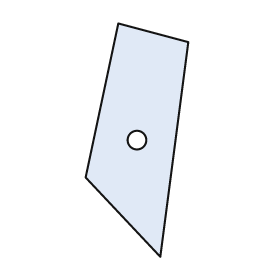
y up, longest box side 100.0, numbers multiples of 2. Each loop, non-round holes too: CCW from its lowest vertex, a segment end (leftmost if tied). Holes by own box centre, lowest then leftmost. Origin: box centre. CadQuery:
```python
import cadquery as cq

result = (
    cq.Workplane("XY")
    .moveTo(10.0, -50.0)
    .lineTo(22.0, 42.0)
    .lineTo(-8.0, 50.0)
    .lineTo(-22.0, -16.0)
    .close()
    .moveTo(0.0, 0.0)
    .circle(4.0)
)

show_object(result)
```